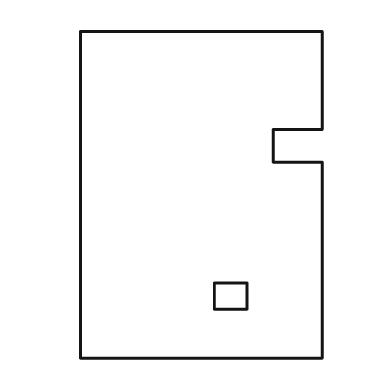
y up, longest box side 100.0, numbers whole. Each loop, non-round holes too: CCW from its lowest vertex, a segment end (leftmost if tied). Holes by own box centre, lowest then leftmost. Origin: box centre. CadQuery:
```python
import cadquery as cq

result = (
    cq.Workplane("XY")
    .moveTo(-37.0, -50.0)
    .lineTo(37.0, -50.0)
    .lineTo(37.0, 10.0)
    .lineTo(22.0, 10.0)
    .lineTo(22.0, 20.0)
    .lineTo(37.0, 20.0)
    .lineTo(37.0, 50.0)
    .lineTo(-37.0, 50.0)
    .close()
    .moveTo(4.0, -35.0)
    .lineTo(14.0, -35.0)
    .lineTo(14.0, -27.0)
    .lineTo(4.0, -27.0)
    .close()
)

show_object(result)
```